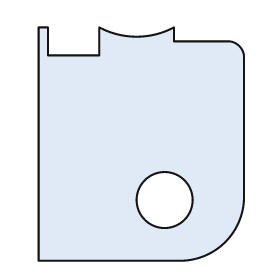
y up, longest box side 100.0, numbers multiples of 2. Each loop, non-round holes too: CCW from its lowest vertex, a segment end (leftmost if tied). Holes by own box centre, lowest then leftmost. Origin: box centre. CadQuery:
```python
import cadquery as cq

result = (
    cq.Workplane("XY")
    .moveTo(-44.0, -50.0)
    .lineTo(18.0, -50.0)
    .threePointArc((36.0, -42.0), (44.0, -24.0))
    .lineTo(44.0, 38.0)
    .threePointArc((42.0, 42.0), (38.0, 44.0))
    .lineTo(14.0, 44.0)
    .lineTo(14.0, 50.0)
    .threePointArc((-2.0, 46.0), (-18.0, 50.0))
    .lineTo(-18.0, 38.0)
    .lineTo(-40.0, 38.0)
    .lineTo(-40.0, 50.0)
    .lineTo(-44.0, 50.0)
    .close()
    .moveTo(10.0, -24.0)
    .circle(12.0)
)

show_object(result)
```